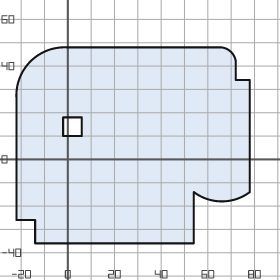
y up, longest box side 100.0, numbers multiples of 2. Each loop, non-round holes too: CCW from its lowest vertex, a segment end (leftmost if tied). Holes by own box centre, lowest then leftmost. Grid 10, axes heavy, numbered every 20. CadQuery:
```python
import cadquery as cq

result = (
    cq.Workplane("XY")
    .moveTo(-14.0, -36.0)
    .lineTo(54.0, -36.0)
    .lineTo(54.0, -14.0)
    .threePointArc((66.0, -18.0), (78.0, -14.0))
    .lineTo(78.0, 34.0)
    .lineTo(72.0, 34.0)
    .lineTo(72.0, 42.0)
    .threePointArc((70.0, 46.0), (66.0, 48.0))
    .lineTo(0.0, 48.0)
    .threePointArc((-16.0, 42.0), (-22.0, 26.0))
    .lineTo(-22.0, -26.0)
    .lineTo(-14.0, -26.0)
    .close()
    .moveTo(-2.0, 10.0)
    .lineTo(6.0, 10.0)
    .lineTo(6.0, 18.0)
    .lineTo(-2.0, 18.0)
    .close()
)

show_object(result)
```